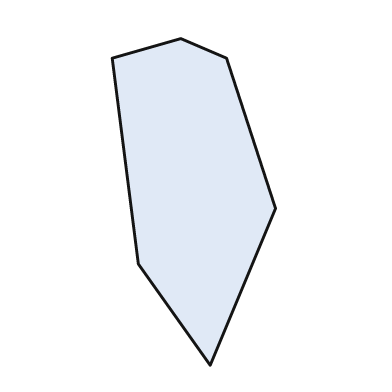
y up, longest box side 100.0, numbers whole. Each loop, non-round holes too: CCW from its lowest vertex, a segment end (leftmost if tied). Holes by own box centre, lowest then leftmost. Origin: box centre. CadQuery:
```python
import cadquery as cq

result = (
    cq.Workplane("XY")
    .moveTo(5.0, -50.0)
    .lineTo(25.0, -2.0)
    .lineTo(10.0, 44.0)
    .lineTo(-4.0, 50.0)
    .lineTo(-25.0, 44.0)
    .lineTo(-17.0, -19.0)
    .close()
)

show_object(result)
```